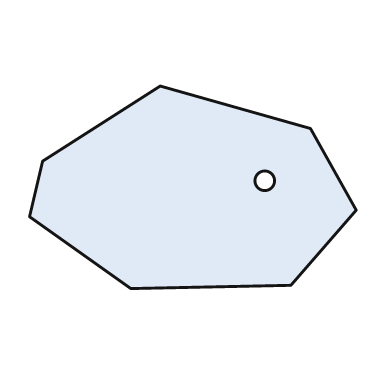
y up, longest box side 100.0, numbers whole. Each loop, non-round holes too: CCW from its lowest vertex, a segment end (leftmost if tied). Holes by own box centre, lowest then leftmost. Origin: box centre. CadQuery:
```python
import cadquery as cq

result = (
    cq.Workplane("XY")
    .moveTo(-19.0, -31.0)
    .lineTo(30.0, -30.0)
    .lineTo(50.0, -7.0)
    .lineTo(36.0, 18.0)
    .lineTo(-10.0, 31.0)
    .lineTo(-46.0, 8.0)
    .lineTo(-50.0, -9.0)
    .close()
    .moveTo(22.0, 2.0)
    .circle(3.0)
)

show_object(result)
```